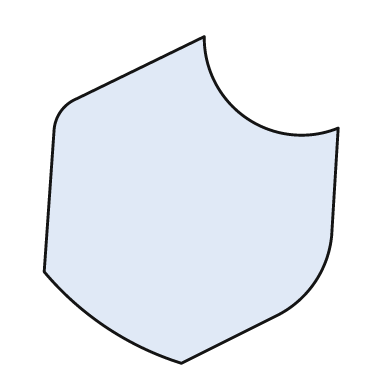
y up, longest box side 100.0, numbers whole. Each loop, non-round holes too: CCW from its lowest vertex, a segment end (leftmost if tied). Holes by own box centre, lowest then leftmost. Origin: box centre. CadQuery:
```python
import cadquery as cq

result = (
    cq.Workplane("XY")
    .moveTo(-3.0, -50.0)
    .lineTo(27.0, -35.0)
    .threePointArc((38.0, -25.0), (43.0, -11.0))
    .lineTo(45.0, 22.0)
    .threePointArc((17.0, 25.0), (4.0, 50.0))
    .lineTo(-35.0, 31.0)
    .threePointArc((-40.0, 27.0), (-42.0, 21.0))
    .lineTo(-45.0, -22.0)
    .threePointArc((-26.0, -39.0), (-3.0, -50.0))
    .close()
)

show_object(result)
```